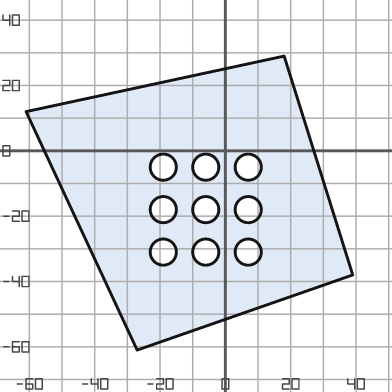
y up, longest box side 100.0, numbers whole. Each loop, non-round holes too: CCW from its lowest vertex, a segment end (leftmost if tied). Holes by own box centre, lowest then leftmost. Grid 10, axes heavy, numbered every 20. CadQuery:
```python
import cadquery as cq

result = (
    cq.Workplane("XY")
    .moveTo(-27.0, -61.0)
    .lineTo(39.0, -38.0)
    .lineTo(18.0, 29.0)
    .lineTo(-61.0, 12.0)
    .close()
    .moveTo(-19.0, -31.0)
    .circle(4.0)
    .moveTo(-6.0, -31.0)
    .circle(4.0)
    .moveTo(7.0, -31.0)
    .circle(4.0)
    .moveTo(-19.0, -18.0)
    .circle(4.0)
    .moveTo(-6.0, -18.0)
    .circle(4.0)
    .moveTo(7.0, -18.0)
    .circle(4.0)
    .moveTo(-19.0, -5.0)
    .circle(4.0)
    .moveTo(-6.0, -5.0)
    .circle(4.0)
    .moveTo(7.0, -5.0)
    .circle(4.0)
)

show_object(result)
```